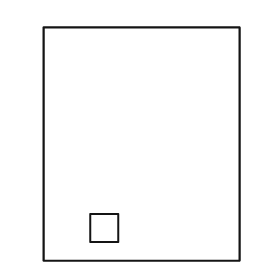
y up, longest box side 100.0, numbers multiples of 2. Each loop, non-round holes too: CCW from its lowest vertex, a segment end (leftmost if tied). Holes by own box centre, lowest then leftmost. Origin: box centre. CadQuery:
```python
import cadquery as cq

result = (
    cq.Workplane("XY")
    .moveTo(-42.0, -50.0)
    .lineTo(42.0, -50.0)
    .lineTo(42.0, 50.0)
    .lineTo(-42.0, 50.0)
    .close()
    .moveTo(-22.0, -42.0)
    .lineTo(-10.0, -42.0)
    .lineTo(-10.0, -30.0)
    .lineTo(-22.0, -30.0)
    .close()
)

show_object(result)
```